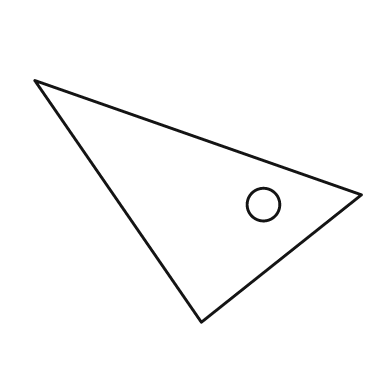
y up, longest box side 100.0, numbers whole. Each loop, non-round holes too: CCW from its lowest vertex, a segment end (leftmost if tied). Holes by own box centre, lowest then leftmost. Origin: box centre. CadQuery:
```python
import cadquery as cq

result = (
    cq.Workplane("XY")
    .moveTo(1.0, -37.0)
    .lineTo(50.0, 2.0)
    .lineTo(-50.0, 37.0)
    .close()
    .moveTo(20.0, -1.0)
    .circle(5.0)
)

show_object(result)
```